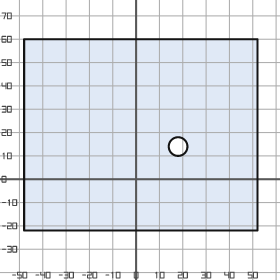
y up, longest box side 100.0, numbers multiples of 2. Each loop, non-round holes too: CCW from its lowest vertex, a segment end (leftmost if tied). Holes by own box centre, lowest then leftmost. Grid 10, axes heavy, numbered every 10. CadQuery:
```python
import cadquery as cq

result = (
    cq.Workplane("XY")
    .moveTo(-48.0, -22.0)
    .lineTo(52.0, -22.0)
    .lineTo(52.0, 60.0)
    .lineTo(-48.0, 60.0)
    .close()
    .moveTo(18.0, 14.0)
    .circle(4.0)
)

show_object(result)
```